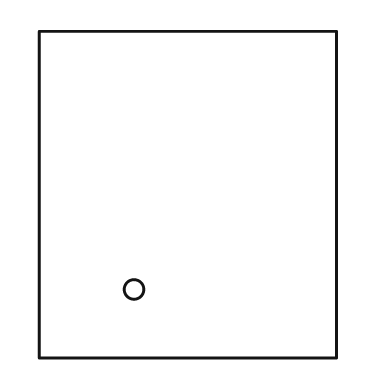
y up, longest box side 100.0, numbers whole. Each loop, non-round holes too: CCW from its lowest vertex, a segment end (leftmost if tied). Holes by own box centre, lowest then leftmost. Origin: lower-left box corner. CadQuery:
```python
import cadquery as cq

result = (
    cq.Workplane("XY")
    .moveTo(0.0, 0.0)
    .lineTo(91.0, 0.0)
    .lineTo(91.0, 100.0)
    .lineTo(0.0, 100.0)
    .close()
    .moveTo(29.0, 21.0)
    .circle(3.0)
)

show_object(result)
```